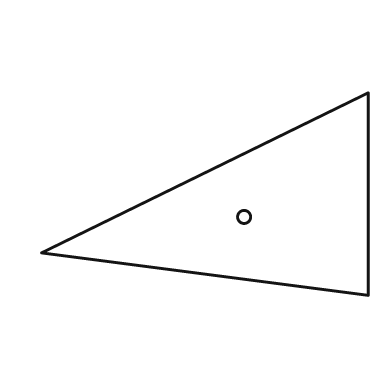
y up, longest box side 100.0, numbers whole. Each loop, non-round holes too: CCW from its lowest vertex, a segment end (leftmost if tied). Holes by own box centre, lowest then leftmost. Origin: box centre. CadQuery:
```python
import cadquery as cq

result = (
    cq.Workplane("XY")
    .moveTo(50.0, -31.0)
    .lineTo(50.0, 31.0)
    .lineTo(-50.0, -18.0)
    .close()
    .moveTo(12.0, -7.0)
    .circle(2.0)
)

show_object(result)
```